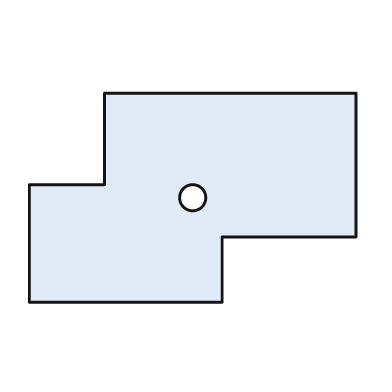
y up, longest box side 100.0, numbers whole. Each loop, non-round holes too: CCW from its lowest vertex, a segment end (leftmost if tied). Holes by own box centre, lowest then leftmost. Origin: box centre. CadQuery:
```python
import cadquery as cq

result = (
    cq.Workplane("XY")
    .moveTo(-50.0, -32.0)
    .lineTo(9.0, -32.0)
    .lineTo(9.0, -12.0)
    .lineTo(50.0, -12.0)
    .lineTo(50.0, 32.0)
    .lineTo(-27.0, 32.0)
    .lineTo(-27.0, 4.0)
    .lineTo(-50.0, 4.0)
    .close()
    .moveTo(0.0, 0.0)
    .circle(4.0)
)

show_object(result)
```